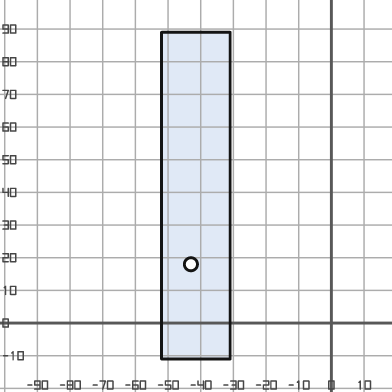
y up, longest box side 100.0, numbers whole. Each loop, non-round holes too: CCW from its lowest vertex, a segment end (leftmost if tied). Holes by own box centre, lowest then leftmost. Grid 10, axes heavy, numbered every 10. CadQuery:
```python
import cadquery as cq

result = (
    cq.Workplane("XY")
    .moveTo(-52.0, -11.0)
    .lineTo(-31.0, -11.0)
    .lineTo(-31.0, 89.0)
    .lineTo(-52.0, 89.0)
    .close()
    .moveTo(-43.0, 18.0)
    .circle(2.0)
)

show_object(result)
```